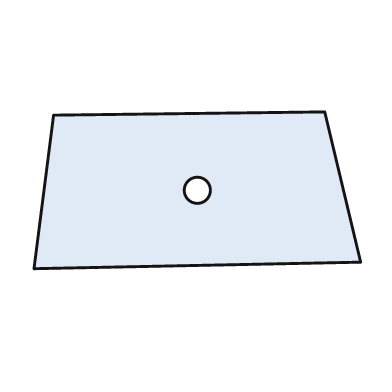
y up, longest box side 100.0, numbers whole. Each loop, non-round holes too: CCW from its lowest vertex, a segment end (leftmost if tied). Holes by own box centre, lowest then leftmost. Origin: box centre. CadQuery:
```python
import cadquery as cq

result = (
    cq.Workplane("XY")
    .moveTo(-50.0, -24.0)
    .lineTo(50.0, -22.0)
    .lineTo(39.0, 24.0)
    .lineTo(-44.0, 23.0)
    .close()
    .moveTo(0.0, 0.0)
    .circle(4.0)
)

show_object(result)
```